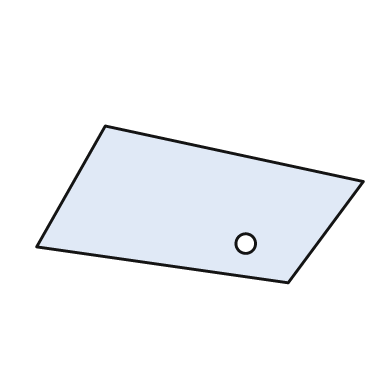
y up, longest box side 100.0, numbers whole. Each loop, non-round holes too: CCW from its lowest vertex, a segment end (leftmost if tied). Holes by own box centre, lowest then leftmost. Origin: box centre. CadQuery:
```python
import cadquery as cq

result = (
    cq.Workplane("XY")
    .moveTo(27.0, -24.0)
    .lineTo(50.0, 7.0)
    .lineTo(-29.0, 24.0)
    .lineTo(-50.0, -13.0)
    .close()
    .moveTo(14.0, -12.0)
    .circle(3.0)
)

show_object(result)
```